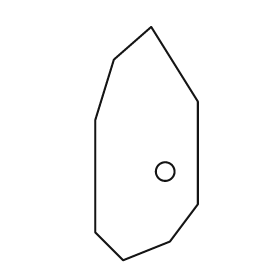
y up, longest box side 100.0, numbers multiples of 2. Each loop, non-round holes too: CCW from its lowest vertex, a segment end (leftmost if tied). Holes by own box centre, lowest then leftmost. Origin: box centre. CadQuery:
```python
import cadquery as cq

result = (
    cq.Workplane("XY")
    .moveTo(-10.0, -50.0)
    .lineTo(10.0, -42.0)
    .lineTo(22.0, -26.0)
    .lineTo(22.0, 18.0)
    .lineTo(2.0, 50.0)
    .lineTo(-14.0, 36.0)
    .lineTo(-22.0, 10.0)
    .lineTo(-22.0, -38.0)
    .close()
    .moveTo(8.0, -12.0)
    .circle(4.0)
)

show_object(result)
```